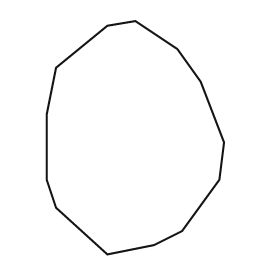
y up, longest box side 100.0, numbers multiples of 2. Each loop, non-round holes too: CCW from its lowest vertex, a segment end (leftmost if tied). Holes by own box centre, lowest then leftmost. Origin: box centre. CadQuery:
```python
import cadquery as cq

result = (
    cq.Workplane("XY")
    .moveTo(-12.0, -50.0)
    .lineTo(8.0, -46.0)
    .lineTo(20.0, -40.0)
    .lineTo(36.0, -18.0)
    .lineTo(38.0, -2.0)
    .lineTo(28.0, 24.0)
    .lineTo(18.0, 38.0)
    .lineTo(0.0, 50.0)
    .lineTo(-12.0, 48.0)
    .lineTo(-34.0, 30.0)
    .lineTo(-38.0, 10.0)
    .lineTo(-38.0, -18.0)
    .lineTo(-34.0, -30.0)
    .close()
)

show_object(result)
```